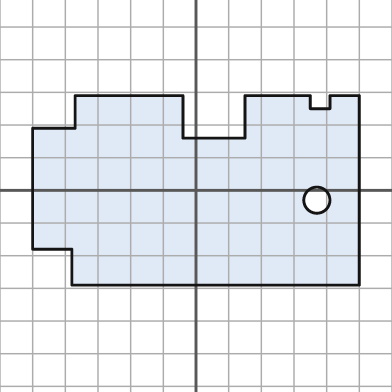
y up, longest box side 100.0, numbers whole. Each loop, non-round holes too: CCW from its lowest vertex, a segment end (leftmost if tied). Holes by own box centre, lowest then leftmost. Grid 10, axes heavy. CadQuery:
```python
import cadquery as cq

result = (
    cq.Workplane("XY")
    .moveTo(-38.0, -29.0)
    .lineTo(50.0, -29.0)
    .lineTo(50.0, 29.0)
    .lineTo(41.0, 29.0)
    .lineTo(41.0, 25.0)
    .lineTo(35.0, 25.0)
    .lineTo(35.0, 29.0)
    .lineTo(15.0, 29.0)
    .lineTo(15.0, 16.0)
    .lineTo(-4.0, 16.0)
    .lineTo(-4.0, 29.0)
    .lineTo(-37.0, 29.0)
    .lineTo(-37.0, 19.0)
    .lineTo(-50.0, 19.0)
    .lineTo(-50.0, -18.0)
    .lineTo(-38.0, -18.0)
    .close()
    .moveTo(37.0, -3.0)
    .circle(4.0)
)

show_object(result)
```